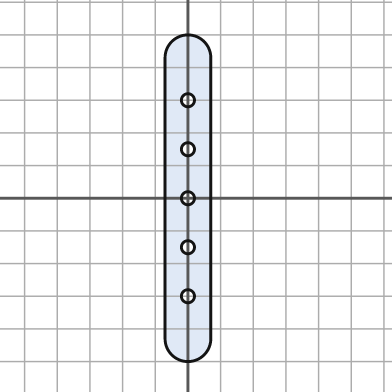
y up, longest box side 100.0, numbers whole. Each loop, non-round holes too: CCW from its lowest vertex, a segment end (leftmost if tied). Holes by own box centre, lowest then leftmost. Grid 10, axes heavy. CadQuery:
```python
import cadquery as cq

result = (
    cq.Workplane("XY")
    .moveTo(-7.0, -43.0)
    .threePointArc((0.0, -50.0), (7.0, -43.0))
    .lineTo(7.0, 43.0)
    .threePointArc((0.0, 50.0), (-7.0, 43.0))
    .close()
    .moveTo(0.0, -30.0)
    .circle(2.0)
    .moveTo(0.0, -15.0)
    .circle(2.0)
    .moveTo(0.0, 0.0)
    .circle(2.0)
    .moveTo(0.0, 15.0)
    .circle(2.0)
    .moveTo(0.0, 30.0)
    .circle(2.0)
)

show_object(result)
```